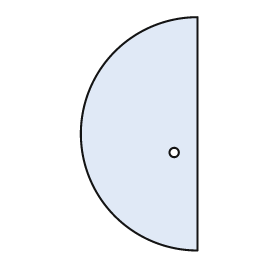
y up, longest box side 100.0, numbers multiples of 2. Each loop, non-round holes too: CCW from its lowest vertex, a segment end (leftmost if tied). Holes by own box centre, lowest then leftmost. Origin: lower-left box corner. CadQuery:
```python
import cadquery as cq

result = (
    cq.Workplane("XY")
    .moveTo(50.0, 0.0)
    .lineTo(50.0, 100.0)
    .threePointArc((0.0, 50.0), (50.0, 0.0))
    .close()
    .moveTo(40.0, 42.0)
    .circle(2.0)
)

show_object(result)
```